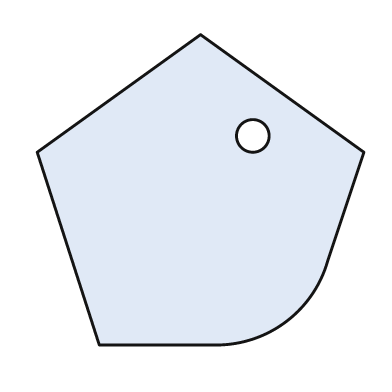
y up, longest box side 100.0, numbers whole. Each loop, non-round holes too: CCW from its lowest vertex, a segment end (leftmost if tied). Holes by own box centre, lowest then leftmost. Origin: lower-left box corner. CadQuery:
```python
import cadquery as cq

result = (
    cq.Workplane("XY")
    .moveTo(19.0, 0.0)
    .lineTo(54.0, 0.0)
    .threePointArc((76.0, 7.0), (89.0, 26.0))
    .lineTo(100.0, 59.0)
    .lineTo(50.0, 95.0)
    .lineTo(0.0, 59.0)
    .close()
    .moveTo(66.0, 64.0)
    .circle(5.0)
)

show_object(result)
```